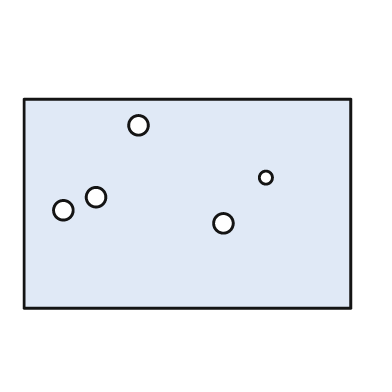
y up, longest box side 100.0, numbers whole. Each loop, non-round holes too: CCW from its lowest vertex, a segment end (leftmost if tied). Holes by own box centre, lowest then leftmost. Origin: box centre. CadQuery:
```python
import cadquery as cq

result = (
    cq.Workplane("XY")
    .moveTo(-50.0, -32.0)
    .lineTo(50.0, -32.0)
    .lineTo(50.0, 32.0)
    .lineTo(-50.0, 32.0)
    .close()
    .moveTo(11.0, -6.0)
    .circle(3.0)
    .moveTo(-38.0, -2.0)
    .circle(3.0)
    .moveTo(-28.0, 2.0)
    .circle(3.0)
    .moveTo(24.0, 8.0)
    .circle(2.0)
    .moveTo(-15.0, 24.0)
    .circle(3.0)
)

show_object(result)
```